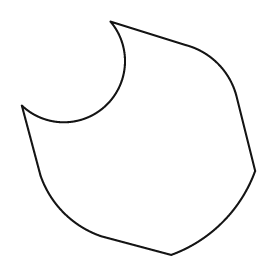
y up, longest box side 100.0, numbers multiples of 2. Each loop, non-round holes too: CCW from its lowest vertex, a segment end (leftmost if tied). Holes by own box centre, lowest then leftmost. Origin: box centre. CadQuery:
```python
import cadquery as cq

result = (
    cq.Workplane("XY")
    .moveTo(14.0, -50.0)
    .threePointArc((36.0, -36.0), (50.0, -14.0))
    .lineTo(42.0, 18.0)
    .threePointArc((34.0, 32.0), (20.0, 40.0))
    .lineTo(-12.0, 50.0)
    .threePointArc((-14.0, 14.0), (-50.0, 14.0))
    .lineTo(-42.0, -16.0)
    .threePointArc((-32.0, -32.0), (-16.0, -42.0))
    .close()
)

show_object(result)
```